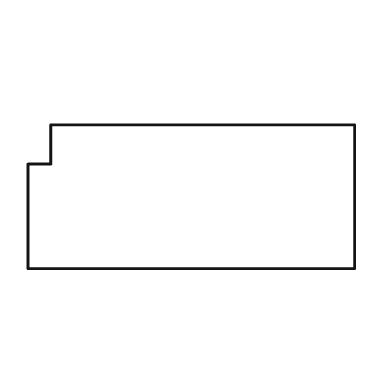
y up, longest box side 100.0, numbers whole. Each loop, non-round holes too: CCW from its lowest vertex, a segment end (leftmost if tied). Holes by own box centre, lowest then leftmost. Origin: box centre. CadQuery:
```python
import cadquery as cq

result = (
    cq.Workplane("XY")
    .moveTo(-50.0, -22.0)
    .lineTo(50.0, -22.0)
    .lineTo(50.0, 22.0)
    .lineTo(-43.0, 22.0)
    .lineTo(-43.0, 10.0)
    .lineTo(-50.0, 10.0)
    .close()
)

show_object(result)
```